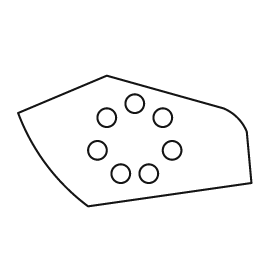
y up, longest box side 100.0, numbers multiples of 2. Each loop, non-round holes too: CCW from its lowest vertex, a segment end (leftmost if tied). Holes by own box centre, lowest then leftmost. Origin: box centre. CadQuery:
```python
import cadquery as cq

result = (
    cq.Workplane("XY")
    .moveTo(-20.0, -28.0)
    .lineTo(50.0, -18.0)
    .lineTo(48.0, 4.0)
    .threePointArc((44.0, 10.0), (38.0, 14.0))
    .lineTo(-12.0, 28.0)
    .lineTo(-50.0, 12.0)
    .threePointArc((-38.0, -10.0), (-20.0, -28.0))
    .close()
    .moveTo(-6.0, -14.0)
    .circle(4.0)
    .moveTo(6.0, -14.0)
    .circle(4.0)
    .moveTo(-16.0, -4.0)
    .circle(4.0)
    .moveTo(16.0, -4.0)
    .circle(4.0)
    .moveTo(-12.0, 10.0)
    .circle(4.0)
    .moveTo(12.0, 10.0)
    .circle(4.0)
    .moveTo(0.0, 16.0)
    .circle(4.0)
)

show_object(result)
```